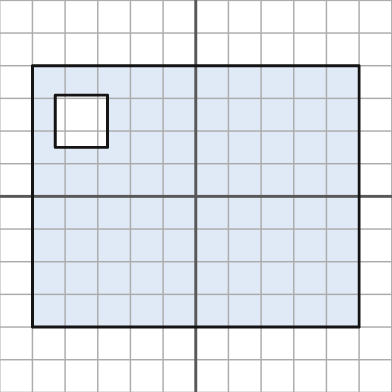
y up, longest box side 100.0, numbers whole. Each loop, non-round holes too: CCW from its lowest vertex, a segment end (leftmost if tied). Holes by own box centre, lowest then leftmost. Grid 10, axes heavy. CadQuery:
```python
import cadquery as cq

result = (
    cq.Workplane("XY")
    .moveTo(-50.0, -40.0)
    .lineTo(50.0, -40.0)
    .lineTo(50.0, 40.0)
    .lineTo(-50.0, 40.0)
    .close()
    .moveTo(-43.0, 15.0)
    .lineTo(-27.0, 15.0)
    .lineTo(-27.0, 31.0)
    .lineTo(-43.0, 31.0)
    .close()
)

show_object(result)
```